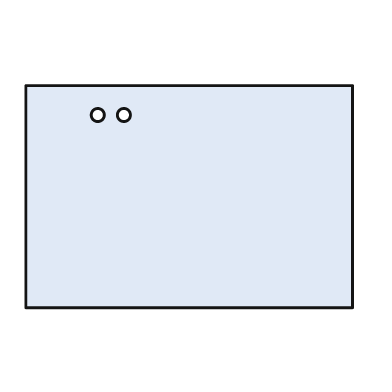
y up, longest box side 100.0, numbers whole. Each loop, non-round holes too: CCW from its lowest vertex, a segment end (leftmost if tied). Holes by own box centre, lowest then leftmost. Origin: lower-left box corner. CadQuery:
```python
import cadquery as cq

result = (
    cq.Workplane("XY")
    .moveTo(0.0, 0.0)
    .lineTo(100.0, 0.0)
    .lineTo(100.0, 68.0)
    .lineTo(0.0, 68.0)
    .close()
    .moveTo(22.0, 59.0)
    .circle(2.0)
    .moveTo(30.0, 59.0)
    .circle(2.0)
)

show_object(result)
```